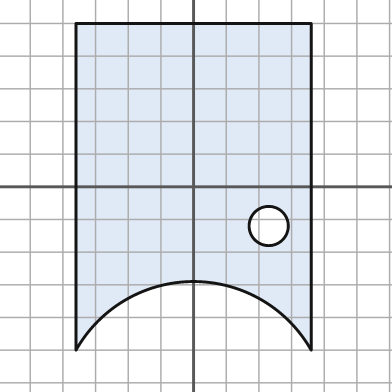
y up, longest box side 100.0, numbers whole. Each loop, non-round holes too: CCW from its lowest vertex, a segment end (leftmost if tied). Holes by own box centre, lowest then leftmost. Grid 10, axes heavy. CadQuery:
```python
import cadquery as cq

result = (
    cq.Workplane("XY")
    .moveTo(-36.0, -50.0)
    .threePointArc((0.0, -29.0), (36.0, -50.0))
    .lineTo(36.0, 50.0)
    .lineTo(-36.0, 50.0)
    .close()
    .moveTo(23.0, -12.0)
    .circle(6.0)
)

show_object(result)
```